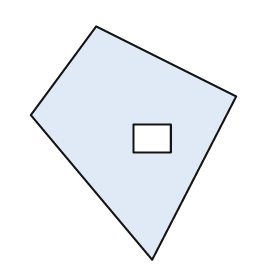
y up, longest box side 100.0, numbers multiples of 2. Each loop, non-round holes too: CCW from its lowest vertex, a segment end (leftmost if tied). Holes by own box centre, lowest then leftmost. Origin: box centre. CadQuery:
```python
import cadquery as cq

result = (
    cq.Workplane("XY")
    .moveTo(8.0, -50.0)
    .lineTo(44.0, 20.0)
    .lineTo(-16.0, 50.0)
    .lineTo(-44.0, 12.0)
    .close()
    .moveTo(0.0, -4.0)
    .lineTo(16.0, -4.0)
    .lineTo(16.0, 8.0)
    .lineTo(0.0, 8.0)
    .close()
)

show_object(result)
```